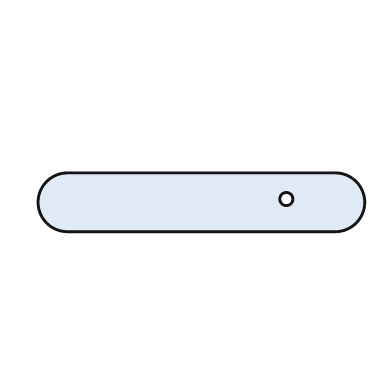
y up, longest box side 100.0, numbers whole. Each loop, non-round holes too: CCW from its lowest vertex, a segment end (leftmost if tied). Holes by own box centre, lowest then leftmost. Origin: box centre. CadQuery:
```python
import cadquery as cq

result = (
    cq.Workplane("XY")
    .moveTo(-41.0, -9.0)
    .lineTo(41.0, -9.0)
    .threePointArc((50.0, 0.0), (41.0, 9.0))
    .lineTo(-41.0, 9.0)
    .threePointArc((-50.0, 0.0), (-41.0, -9.0))
    .close()
    .moveTo(26.0, 1.0)
    .circle(2.0)
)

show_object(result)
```